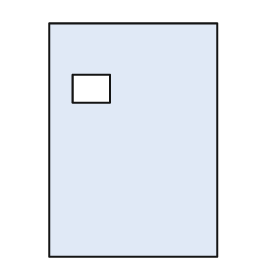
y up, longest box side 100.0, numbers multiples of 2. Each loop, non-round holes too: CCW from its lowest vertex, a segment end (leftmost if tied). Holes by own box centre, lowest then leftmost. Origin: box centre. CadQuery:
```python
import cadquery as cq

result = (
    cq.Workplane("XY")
    .moveTo(-36.0, -50.0)
    .lineTo(36.0, -50.0)
    .lineTo(36.0, 50.0)
    .lineTo(-36.0, 50.0)
    .close()
    .moveTo(-26.0, 16.0)
    .lineTo(-10.0, 16.0)
    .lineTo(-10.0, 28.0)
    .lineTo(-26.0, 28.0)
    .close()
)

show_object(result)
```